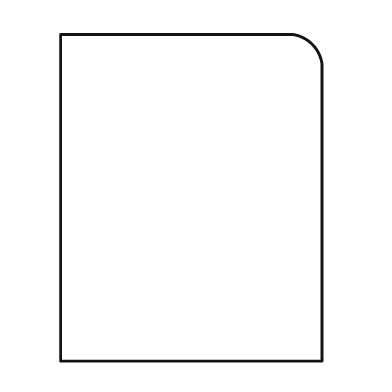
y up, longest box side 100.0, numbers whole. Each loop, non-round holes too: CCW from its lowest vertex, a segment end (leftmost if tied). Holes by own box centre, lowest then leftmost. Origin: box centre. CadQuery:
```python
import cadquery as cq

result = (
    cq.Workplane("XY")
    .moveTo(-40.0, -50.0)
    .lineTo(40.0, -50.0)
    .lineTo(40.0, 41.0)
    .threePointArc((37.0, 47.0), (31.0, 50.0))
    .lineTo(-40.0, 50.0)
    .close()
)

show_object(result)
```